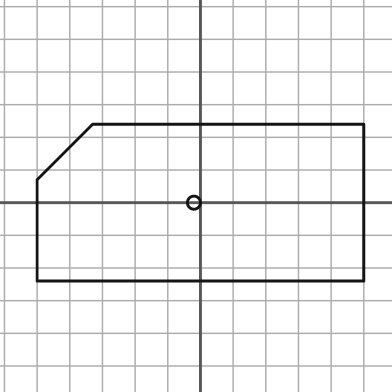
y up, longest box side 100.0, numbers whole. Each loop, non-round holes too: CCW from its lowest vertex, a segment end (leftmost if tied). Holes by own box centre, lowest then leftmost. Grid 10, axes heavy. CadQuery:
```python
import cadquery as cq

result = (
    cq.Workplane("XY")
    .moveTo(-50.0, -24.0)
    .lineTo(50.0, -24.0)
    .lineTo(50.0, 24.0)
    .lineTo(-33.0, 24.0)
    .lineTo(-50.0, 7.0)
    .close()
    .moveTo(-2.0, 0.0)
    .circle(2.0)
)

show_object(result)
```